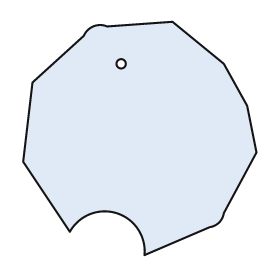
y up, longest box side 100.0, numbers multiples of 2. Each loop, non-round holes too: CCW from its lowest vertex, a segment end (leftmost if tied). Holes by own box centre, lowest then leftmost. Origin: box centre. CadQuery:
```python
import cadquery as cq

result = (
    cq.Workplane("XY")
    .moveTo(2.0, -50.0)
    .lineTo(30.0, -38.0)
    .threePointArc((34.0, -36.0), (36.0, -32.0))
    .lineTo(50.0, -6.0)
    .lineTo(46.0, 14.0)
    .lineTo(36.0, 32.0)
    .lineTo(14.0, 50.0)
    .lineTo(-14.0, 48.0)
    .threePointArc((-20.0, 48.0), (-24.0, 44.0))
    .lineTo(-46.0, 24.0)
    .lineTo(-50.0, -10.0)
    .lineTo(-30.0, -40.0)
    .threePointArc((-10.0, -32.0), (2.0, -50.0))
    .close()
    .moveTo(-8.0, 32.0)
    .circle(2.0)
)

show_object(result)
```